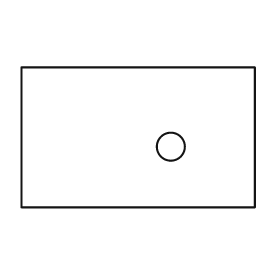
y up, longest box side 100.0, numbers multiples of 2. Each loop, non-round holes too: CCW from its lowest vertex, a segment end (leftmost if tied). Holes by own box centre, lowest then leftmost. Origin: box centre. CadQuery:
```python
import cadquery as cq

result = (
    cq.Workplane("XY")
    .moveTo(-50.0, -30.0)
    .lineTo(50.0, -30.0)
    .lineTo(50.0, 30.0)
    .lineTo(-50.0, 30.0)
    .close()
    .moveTo(14.0, -4.0)
    .circle(6.0)
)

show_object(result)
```